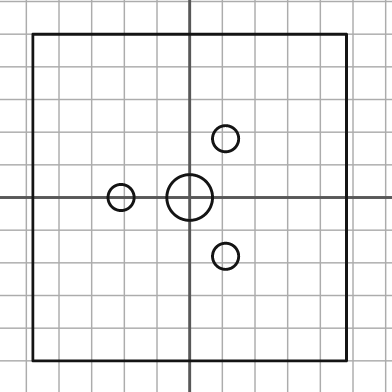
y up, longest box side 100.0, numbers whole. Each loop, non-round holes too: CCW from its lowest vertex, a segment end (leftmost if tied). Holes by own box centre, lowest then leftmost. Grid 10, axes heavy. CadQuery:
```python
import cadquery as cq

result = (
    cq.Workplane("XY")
    .moveTo(-48.0, -50.0)
    .lineTo(48.0, -50.0)
    .lineTo(48.0, 50.0)
    .lineTo(-48.0, 50.0)
    .close()
    .moveTo(11.0, -18.0)
    .circle(4.0)
    .moveTo(-21.0, 0.0)
    .circle(4.0)
    .moveTo(0.0, 0.0)
    .circle(7.0)
    .moveTo(11.0, 18.0)
    .circle(4.0)
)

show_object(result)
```